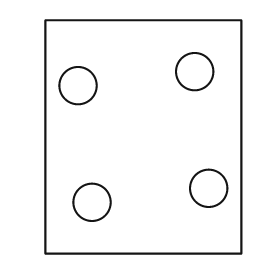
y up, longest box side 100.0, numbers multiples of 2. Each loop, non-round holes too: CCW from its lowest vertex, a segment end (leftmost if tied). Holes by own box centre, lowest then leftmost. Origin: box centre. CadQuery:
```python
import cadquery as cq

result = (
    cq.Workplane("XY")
    .moveTo(-42.0, -50.0)
    .lineTo(42.0, -50.0)
    .lineTo(42.0, 50.0)
    .lineTo(-42.0, 50.0)
    .close()
    .moveTo(-22.0, -28.0)
    .circle(8.0)
    .moveTo(28.0, -22.0)
    .circle(8.0)
    .moveTo(-28.0, 22.0)
    .circle(8.0)
    .moveTo(22.0, 28.0)
    .circle(8.0)
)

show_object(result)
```